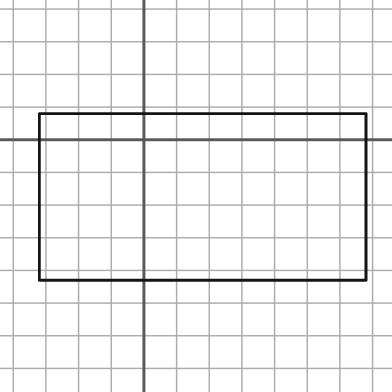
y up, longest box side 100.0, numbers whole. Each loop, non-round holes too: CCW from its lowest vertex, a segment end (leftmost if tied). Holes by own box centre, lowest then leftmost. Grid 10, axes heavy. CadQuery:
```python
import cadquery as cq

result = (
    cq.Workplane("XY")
    .moveTo(-32.0, -43.0)
    .lineTo(68.0, -43.0)
    .lineTo(68.0, 8.0)
    .lineTo(-32.0, 8.0)
    .close()
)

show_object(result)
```